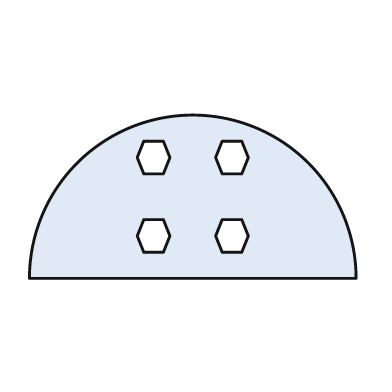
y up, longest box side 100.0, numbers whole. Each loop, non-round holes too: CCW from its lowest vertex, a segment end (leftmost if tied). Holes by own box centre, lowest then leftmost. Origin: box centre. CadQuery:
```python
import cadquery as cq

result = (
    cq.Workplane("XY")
    .moveTo(-50.0, -25.0)
    .lineTo(50.0, -25.0)
    .threePointArc((0.0, 25.0), (-50.0, -25.0))
    .close()
    .moveTo(-15.0, -17.0)
    .lineTo(-9.0, -17.0)
    .lineTo(-7.0, -12.0)
    .lineTo(-9.0, -7.0)
    .lineTo(-15.0, -7.0)
    .lineTo(-17.0, -12.0)
    .close()
    .moveTo(9.0, -17.0)
    .lineTo(15.0, -17.0)
    .lineTo(17.0, -12.0)
    .lineTo(15.0, -7.0)
    .lineTo(9.0, -7.0)
    .lineTo(7.0, -12.0)
    .close()
    .moveTo(-15.0, 7.0)
    .lineTo(-9.0, 7.0)
    .lineTo(-7.0, 12.0)
    .lineTo(-9.0, 17.0)
    .lineTo(-15.0, 17.0)
    .lineTo(-17.0, 12.0)
    .close()
    .moveTo(9.0, 7.0)
    .lineTo(15.0, 7.0)
    .lineTo(17.0, 12.0)
    .lineTo(15.0, 17.0)
    .lineTo(9.0, 17.0)
    .lineTo(7.0, 12.0)
    .close()
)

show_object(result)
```